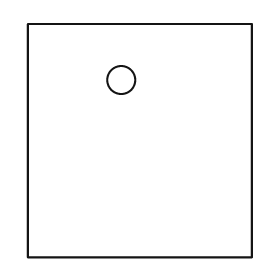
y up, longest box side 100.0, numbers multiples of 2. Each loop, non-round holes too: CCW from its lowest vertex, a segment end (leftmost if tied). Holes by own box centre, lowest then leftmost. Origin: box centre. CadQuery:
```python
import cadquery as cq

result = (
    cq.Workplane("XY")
    .moveTo(-48.0, -50.0)
    .lineTo(48.0, -50.0)
    .lineTo(48.0, 50.0)
    .lineTo(-48.0, 50.0)
    .close()
    .moveTo(-8.0, 26.0)
    .circle(6.0)
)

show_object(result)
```